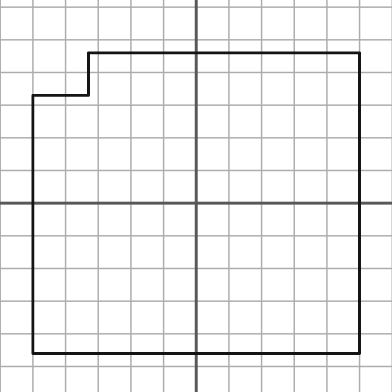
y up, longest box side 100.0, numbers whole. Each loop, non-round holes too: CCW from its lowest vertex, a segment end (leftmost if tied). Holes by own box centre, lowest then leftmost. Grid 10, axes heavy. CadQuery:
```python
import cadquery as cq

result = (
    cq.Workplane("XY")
    .moveTo(-50.0, -46.0)
    .lineTo(50.0, -46.0)
    .lineTo(50.0, 46.0)
    .lineTo(-33.0, 46.0)
    .lineTo(-33.0, 33.0)
    .lineTo(-50.0, 33.0)
    .close()
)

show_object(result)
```